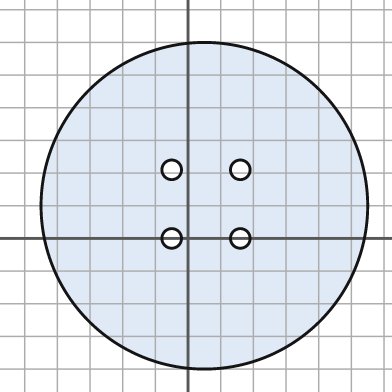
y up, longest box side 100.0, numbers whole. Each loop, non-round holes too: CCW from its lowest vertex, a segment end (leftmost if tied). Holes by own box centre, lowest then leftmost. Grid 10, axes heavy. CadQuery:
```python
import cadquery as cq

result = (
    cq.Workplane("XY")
    .moveTo(5.0, 10.0)
    .circle(50.0)
    .moveTo(-5.0, 0.0)
    .circle(3.0)
    .moveTo(16.0, 0.0)
    .circle(3.0)
    .moveTo(-5.0, 21.0)
    .circle(3.0)
    .moveTo(16.0, 21.0)
    .circle(3.0)
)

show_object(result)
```